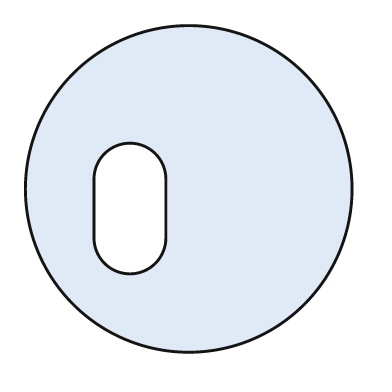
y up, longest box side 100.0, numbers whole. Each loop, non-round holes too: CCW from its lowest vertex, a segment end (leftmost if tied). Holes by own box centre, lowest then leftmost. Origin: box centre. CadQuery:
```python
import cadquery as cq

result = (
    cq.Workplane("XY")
    .moveTo(0.0, 0.0)
    .circle(50.0)
    .moveTo(-29.0, -15.0)
    .threePointArc((-18.0, -26.0), (-7.0, -15.0))
    .lineTo(-7.0, 3.0)
    .threePointArc((-18.0, 14.0), (-29.0, 3.0))
    .close()
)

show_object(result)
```